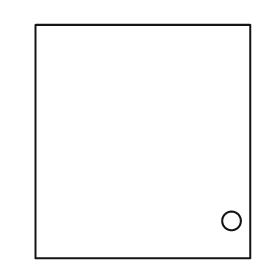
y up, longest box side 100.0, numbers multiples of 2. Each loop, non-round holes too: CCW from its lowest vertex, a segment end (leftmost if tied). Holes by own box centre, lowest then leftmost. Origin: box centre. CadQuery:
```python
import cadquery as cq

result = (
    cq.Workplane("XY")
    .moveTo(-46.0, -50.0)
    .lineTo(46.0, -50.0)
    .lineTo(46.0, 50.0)
    .lineTo(-46.0, 50.0)
    .close()
    .moveTo(38.0, -34.0)
    .circle(4.0)
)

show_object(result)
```